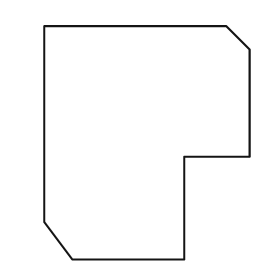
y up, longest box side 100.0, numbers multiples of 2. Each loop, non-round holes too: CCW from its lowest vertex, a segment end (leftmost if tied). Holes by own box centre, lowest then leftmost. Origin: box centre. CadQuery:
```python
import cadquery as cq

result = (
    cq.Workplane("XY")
    .moveTo(-32.0, -50.0)
    .lineTo(16.0, -50.0)
    .lineTo(16.0, -6.0)
    .lineTo(44.0, -6.0)
    .lineTo(44.0, 40.0)
    .lineTo(34.0, 50.0)
    .lineTo(-44.0, 50.0)
    .lineTo(-44.0, -34.0)
    .close()
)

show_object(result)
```